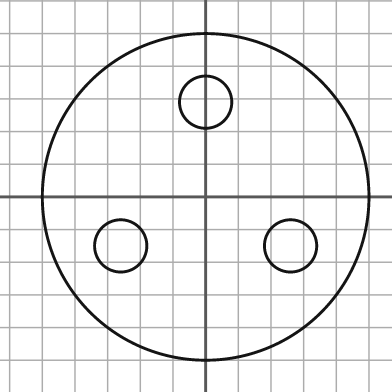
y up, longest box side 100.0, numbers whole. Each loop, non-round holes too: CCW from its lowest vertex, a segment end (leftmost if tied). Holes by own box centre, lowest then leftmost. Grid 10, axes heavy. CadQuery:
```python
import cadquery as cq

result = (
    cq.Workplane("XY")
    .moveTo(0.0, 0.0)
    .circle(50.0)
    .moveTo(-26.0, -15.0)
    .circle(8.0)
    .moveTo(26.0, -15.0)
    .circle(8.0)
    .moveTo(0.0, 29.0)
    .circle(8.0)
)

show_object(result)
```